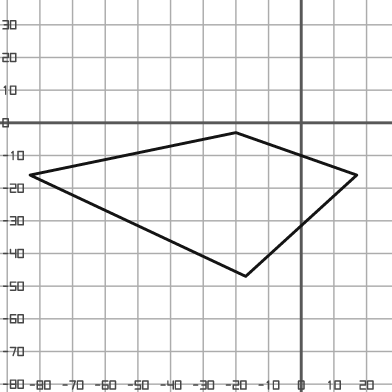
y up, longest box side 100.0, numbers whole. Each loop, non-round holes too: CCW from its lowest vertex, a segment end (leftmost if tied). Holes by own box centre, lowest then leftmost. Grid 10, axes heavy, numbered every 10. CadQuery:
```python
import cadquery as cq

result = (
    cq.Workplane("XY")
    .moveTo(-17.0, -47.0)
    .lineTo(17.0, -16.0)
    .lineTo(-20.0, -3.0)
    .lineTo(-83.0, -16.0)
    .close()
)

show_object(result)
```